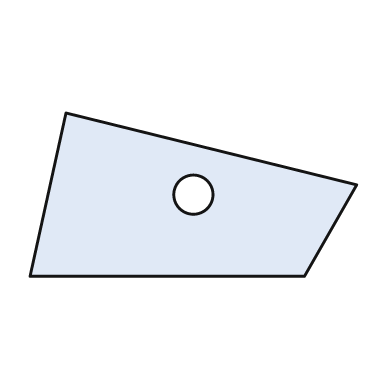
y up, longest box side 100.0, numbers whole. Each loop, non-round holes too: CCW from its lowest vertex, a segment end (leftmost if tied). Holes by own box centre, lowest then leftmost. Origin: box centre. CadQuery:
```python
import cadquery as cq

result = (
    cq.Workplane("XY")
    .moveTo(-50.0, -25.0)
    .lineTo(34.0, -25.0)
    .lineTo(50.0, 3.0)
    .lineTo(-39.0, 25.0)
    .close()
    .moveTo(0.0, 0.0)
    .circle(6.0)
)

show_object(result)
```